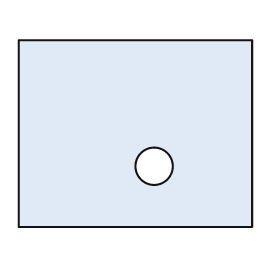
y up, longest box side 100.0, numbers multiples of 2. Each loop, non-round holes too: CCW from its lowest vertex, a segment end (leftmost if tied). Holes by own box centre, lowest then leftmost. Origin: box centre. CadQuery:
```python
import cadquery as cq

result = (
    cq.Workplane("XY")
    .moveTo(-50.0, -40.0)
    .lineTo(50.0, -40.0)
    .lineTo(50.0, 40.0)
    .lineTo(-50.0, 40.0)
    .close()
    .moveTo(8.0, -14.0)
    .circle(8.0)
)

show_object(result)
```